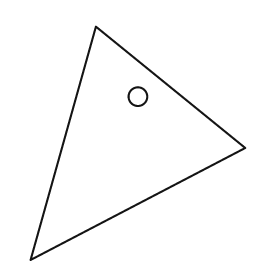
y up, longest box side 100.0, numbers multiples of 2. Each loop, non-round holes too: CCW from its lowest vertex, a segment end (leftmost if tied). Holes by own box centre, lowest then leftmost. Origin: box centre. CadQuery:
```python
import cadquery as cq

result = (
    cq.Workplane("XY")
    .moveTo(-46.0, -50.0)
    .lineTo(46.0, -2.0)
    .lineTo(-18.0, 50.0)
    .close()
    .moveTo(0.0, 20.0)
    .circle(4.0)
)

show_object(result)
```